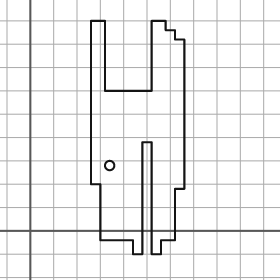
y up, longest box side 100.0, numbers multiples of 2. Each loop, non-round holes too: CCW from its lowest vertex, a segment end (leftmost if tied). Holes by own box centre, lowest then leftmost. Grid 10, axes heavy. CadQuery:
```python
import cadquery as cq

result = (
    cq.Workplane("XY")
    .moveTo(44.0, -10.0)
    .lineTo(48.0, -10.0)
    .lineTo(48.0, 38.0)
    .lineTo(52.0, 38.0)
    .lineTo(52.0, -10.0)
    .lineTo(56.0, -10.0)
    .lineTo(56.0, -4.0)
    .lineTo(62.0, -4.0)
    .lineTo(62.0, 18.0)
    .lineTo(66.0, 18.0)
    .lineTo(66.0, 82.0)
    .lineTo(62.0, 82.0)
    .lineTo(62.0, 86.0)
    .lineTo(58.0, 86.0)
    .lineTo(58.0, 90.0)
    .lineTo(52.0, 90.0)
    .lineTo(52.0, 60.0)
    .lineTo(32.0, 60.0)
    .lineTo(32.0, 90.0)
    .lineTo(26.0, 90.0)
    .lineTo(26.0, 20.0)
    .lineTo(30.0, 20.0)
    .lineTo(30.0, -4.0)
    .lineTo(44.0, -4.0)
    .close()
    .moveTo(34.0, 28.0)
    .circle(2.0)
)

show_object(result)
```